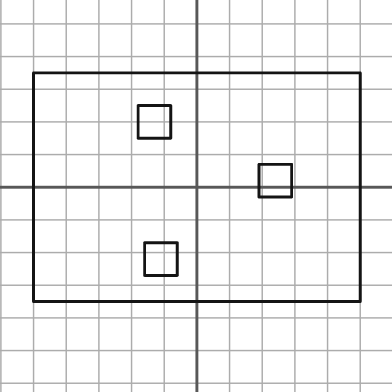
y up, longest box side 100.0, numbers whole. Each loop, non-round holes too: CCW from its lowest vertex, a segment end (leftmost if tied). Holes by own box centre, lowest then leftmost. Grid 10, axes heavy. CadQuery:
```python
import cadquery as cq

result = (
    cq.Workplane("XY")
    .moveTo(-50.0, -35.0)
    .lineTo(50.0, -35.0)
    .lineTo(50.0, 35.0)
    .lineTo(-50.0, 35.0)
    .close()
    .moveTo(-16.0, -27.0)
    .lineTo(-6.0, -27.0)
    .lineTo(-6.0, -17.0)
    .lineTo(-16.0, -17.0)
    .close()
    .moveTo(19.0, -3.0)
    .lineTo(29.0, -3.0)
    .lineTo(29.0, 7.0)
    .lineTo(19.0, 7.0)
    .close()
    .moveTo(-18.0, 15.0)
    .lineTo(-8.0, 15.0)
    .lineTo(-8.0, 25.0)
    .lineTo(-18.0, 25.0)
    .close()
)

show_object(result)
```